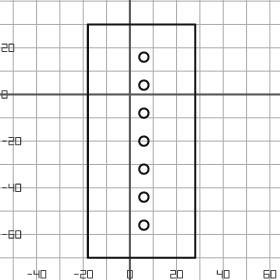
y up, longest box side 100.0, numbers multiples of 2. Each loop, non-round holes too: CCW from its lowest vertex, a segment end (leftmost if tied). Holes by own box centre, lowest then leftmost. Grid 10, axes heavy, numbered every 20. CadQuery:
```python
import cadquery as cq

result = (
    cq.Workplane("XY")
    .moveTo(-18.0, -70.0)
    .lineTo(28.0, -70.0)
    .lineTo(28.0, 30.0)
    .lineTo(-18.0, 30.0)
    .close()
    .moveTo(6.0, -56.0)
    .circle(2.0)
    .moveTo(6.0, -44.0)
    .circle(2.0)
    .moveTo(6.0, -32.0)
    .circle(2.0)
    .moveTo(6.0, -20.0)
    .circle(2.0)
    .moveTo(6.0, -8.0)
    .circle(2.0)
    .moveTo(6.0, 4.0)
    .circle(2.0)
    .moveTo(6.0, 16.0)
    .circle(2.0)
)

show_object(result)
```